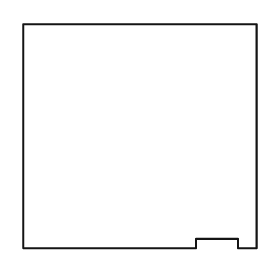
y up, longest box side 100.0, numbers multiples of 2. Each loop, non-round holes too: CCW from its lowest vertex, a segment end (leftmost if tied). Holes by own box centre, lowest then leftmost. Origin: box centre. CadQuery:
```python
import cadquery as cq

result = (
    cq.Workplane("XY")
    .moveTo(-50.0, -48.0)
    .lineTo(24.0, -48.0)
    .lineTo(24.0, -44.0)
    .lineTo(42.0, -44.0)
    .lineTo(42.0, -48.0)
    .lineTo(50.0, -48.0)
    .lineTo(50.0, 48.0)
    .lineTo(-50.0, 48.0)
    .close()
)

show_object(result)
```